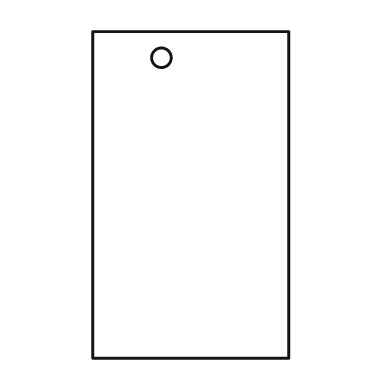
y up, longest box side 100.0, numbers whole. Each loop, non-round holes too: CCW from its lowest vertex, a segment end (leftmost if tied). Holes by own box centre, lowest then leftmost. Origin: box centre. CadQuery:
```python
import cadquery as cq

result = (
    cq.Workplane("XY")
    .moveTo(-30.0, -50.0)
    .lineTo(30.0, -50.0)
    .lineTo(30.0, 50.0)
    .lineTo(-30.0, 50.0)
    .close()
    .moveTo(-9.0, 42.0)
    .circle(3.0)
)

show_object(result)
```